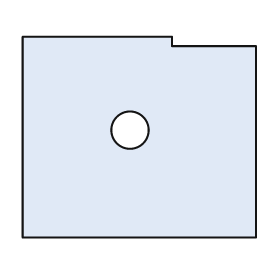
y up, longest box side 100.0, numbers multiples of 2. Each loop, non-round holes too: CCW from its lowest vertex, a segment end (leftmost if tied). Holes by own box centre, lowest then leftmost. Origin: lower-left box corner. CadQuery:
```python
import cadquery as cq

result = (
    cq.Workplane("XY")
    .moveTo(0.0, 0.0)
    .lineTo(100.0, 0.0)
    .lineTo(100.0, 82.0)
    .lineTo(64.0, 82.0)
    .lineTo(64.0, 86.0)
    .lineTo(0.0, 86.0)
    .close()
    .moveTo(46.0, 46.0)
    .circle(8.0)
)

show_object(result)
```